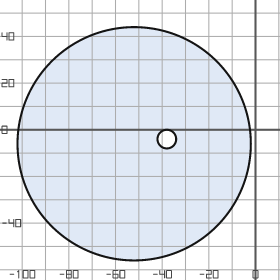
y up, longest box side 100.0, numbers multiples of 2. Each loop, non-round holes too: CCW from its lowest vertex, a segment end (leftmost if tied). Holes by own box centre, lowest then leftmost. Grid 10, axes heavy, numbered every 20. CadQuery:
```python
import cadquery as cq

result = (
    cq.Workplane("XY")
    .moveTo(-52.0, -6.0)
    .circle(50.0)
    .moveTo(-38.0, -4.0)
    .circle(4.0)
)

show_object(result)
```